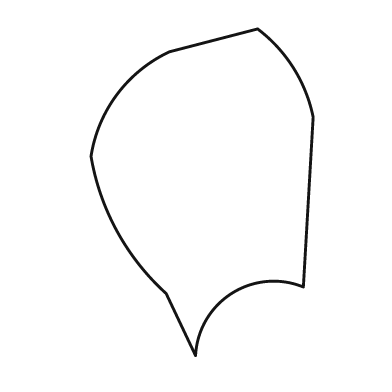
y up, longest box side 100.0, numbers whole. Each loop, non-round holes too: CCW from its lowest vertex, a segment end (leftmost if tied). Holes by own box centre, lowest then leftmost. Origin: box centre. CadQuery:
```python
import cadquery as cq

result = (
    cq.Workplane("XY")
    .moveTo(-2.0, -50.0)
    .threePointArc((9.0, -31.0), (31.0, -29.0))
    .lineTo(34.0, 23.0)
    .threePointArc((28.0, 38.0), (17.0, 50.0))
    .lineTo(-10.0, 43.0)
    .threePointArc((-26.0, 30.0), (-34.0, 11.0))
    .threePointArc((-26.0, -12.0), (-11.0, -31.0))
    .close()
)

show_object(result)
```